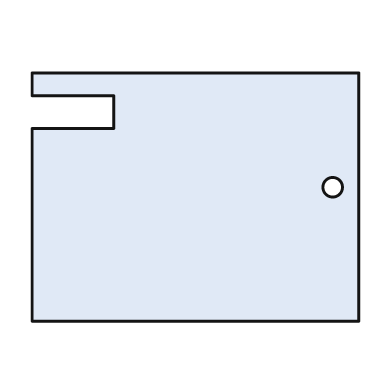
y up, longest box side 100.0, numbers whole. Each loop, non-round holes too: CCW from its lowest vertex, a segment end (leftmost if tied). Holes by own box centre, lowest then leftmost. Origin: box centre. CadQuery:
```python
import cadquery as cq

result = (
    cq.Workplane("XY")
    .moveTo(-50.0, -38.0)
    .lineTo(50.0, -38.0)
    .lineTo(50.0, 38.0)
    .lineTo(-50.0, 38.0)
    .lineTo(-50.0, 31.0)
    .lineTo(-25.0, 31.0)
    .lineTo(-25.0, 21.0)
    .lineTo(-50.0, 21.0)
    .close()
    .moveTo(42.0, 3.0)
    .circle(3.0)
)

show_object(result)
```